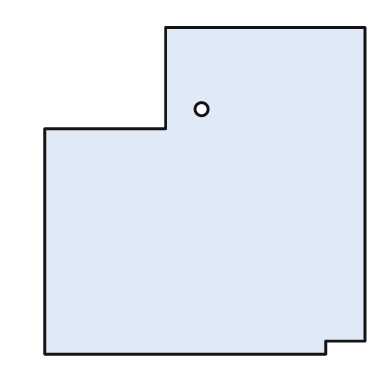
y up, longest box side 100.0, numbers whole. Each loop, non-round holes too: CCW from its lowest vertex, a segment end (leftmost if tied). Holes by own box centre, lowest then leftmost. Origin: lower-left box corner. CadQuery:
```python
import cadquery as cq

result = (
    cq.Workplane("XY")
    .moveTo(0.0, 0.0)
    .lineTo(86.0, 0.0)
    .lineTo(86.0, 4.0)
    .lineTo(98.0, 4.0)
    .lineTo(98.0, 100.0)
    .lineTo(37.0, 100.0)
    .lineTo(37.0, 69.0)
    .lineTo(0.0, 69.0)
    .close()
    .moveTo(48.0, 75.0)
    .circle(2.0)
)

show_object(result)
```